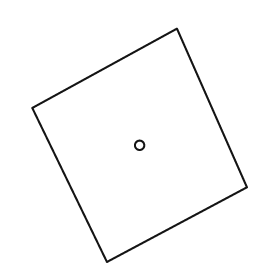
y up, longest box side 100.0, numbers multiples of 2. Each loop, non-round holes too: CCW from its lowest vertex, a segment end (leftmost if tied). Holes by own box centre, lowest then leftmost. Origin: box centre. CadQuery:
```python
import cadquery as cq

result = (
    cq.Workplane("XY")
    .moveTo(-14.0, -50.0)
    .lineTo(46.0, -18.0)
    .lineTo(16.0, 50.0)
    .lineTo(-46.0, 16.0)
    .close()
    .moveTo(0.0, 0.0)
    .circle(2.0)
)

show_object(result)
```